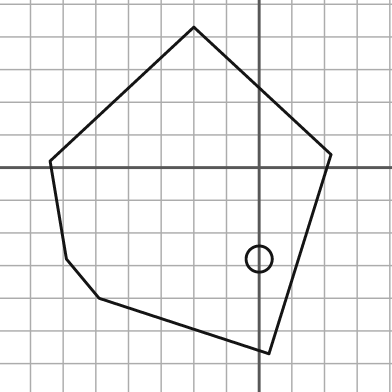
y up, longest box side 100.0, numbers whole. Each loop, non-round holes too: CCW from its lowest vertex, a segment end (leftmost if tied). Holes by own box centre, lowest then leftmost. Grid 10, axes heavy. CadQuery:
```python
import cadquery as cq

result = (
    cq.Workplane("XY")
    .moveTo(3.0, -57.0)
    .lineTo(22.0, 4.0)
    .lineTo(-20.0, 43.0)
    .lineTo(-64.0, 2.0)
    .lineTo(-59.0, -28.0)
    .lineTo(-49.0, -40.0)
    .close()
    .moveTo(0.0, -28.0)
    .circle(4.0)
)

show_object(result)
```